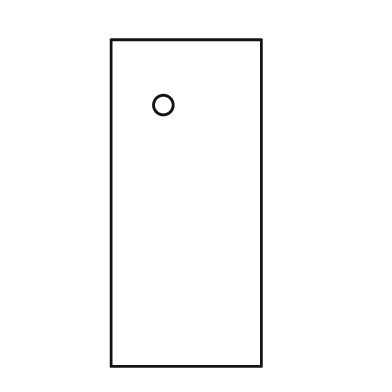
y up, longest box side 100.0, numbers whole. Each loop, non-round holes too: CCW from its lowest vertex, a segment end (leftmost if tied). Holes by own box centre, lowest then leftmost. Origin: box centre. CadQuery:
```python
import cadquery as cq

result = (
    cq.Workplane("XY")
    .moveTo(-23.0, -50.0)
    .lineTo(23.0, -50.0)
    .lineTo(23.0, 50.0)
    .lineTo(-23.0, 50.0)
    .close()
    .moveTo(-7.0, 30.0)
    .circle(3.0)
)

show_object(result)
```